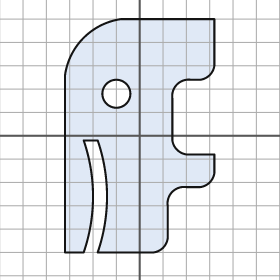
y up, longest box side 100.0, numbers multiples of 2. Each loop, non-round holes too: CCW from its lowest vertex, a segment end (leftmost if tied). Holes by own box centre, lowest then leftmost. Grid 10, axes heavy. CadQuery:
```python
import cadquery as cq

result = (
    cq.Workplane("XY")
    .moveTo(-32.0, -50.0)
    .lineTo(-24.0, -50.0)
    .threePointArc((-20.0, -26.0), (-24.0, -2.0))
    .lineTo(-18.0, -2.0)
    .threePointArc((-14.0, -26.0), (-18.0, -50.0))
    .lineTo(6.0, -50.0)
    .threePointArc((10.0, -48.0), (12.0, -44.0))
    .lineTo(12.0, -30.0)
    .threePointArc((14.0, -24.0), (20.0, -22.0))
    .lineTo(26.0, -22.0)
    .threePointArc((30.0, -20.0), (32.0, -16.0))
    .lineTo(32.0, -8.0)
    .lineTo(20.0, -8.0)
    .threePointArc((16.0, -6.0), (14.0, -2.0))
    .lineTo(14.0, 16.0)
    .threePointArc((16.0, 22.0), (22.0, 24.0))
    .lineTo(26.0, 24.0)
    .threePointArc((30.0, 26.0), (32.0, 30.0))
    .lineTo(32.0, 50.0)
    .lineTo(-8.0, 50.0)
    .threePointArc((-24.0, 42.0), (-32.0, 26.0))
    .close()
    .moveTo(-10.0, 18.0)
    .circle(6.0)
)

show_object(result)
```